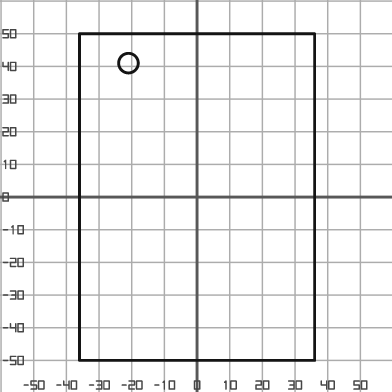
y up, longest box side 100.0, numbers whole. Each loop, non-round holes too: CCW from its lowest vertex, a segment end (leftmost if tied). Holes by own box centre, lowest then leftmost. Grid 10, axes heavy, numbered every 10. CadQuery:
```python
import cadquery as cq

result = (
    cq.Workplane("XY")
    .moveTo(-36.0, -50.0)
    .lineTo(36.0, -50.0)
    .lineTo(36.0, 50.0)
    .lineTo(-36.0, 50.0)
    .close()
    .moveTo(-21.0, 41.0)
    .circle(3.0)
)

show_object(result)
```